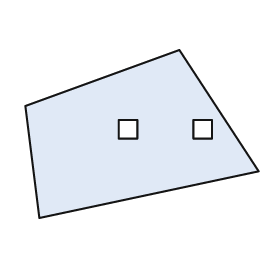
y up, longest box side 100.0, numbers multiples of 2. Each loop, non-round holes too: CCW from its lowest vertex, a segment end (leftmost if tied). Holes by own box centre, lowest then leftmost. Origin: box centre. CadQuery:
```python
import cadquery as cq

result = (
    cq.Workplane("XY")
    .moveTo(-44.0, -36.0)
    .lineTo(50.0, -16.0)
    .lineTo(16.0, 36.0)
    .lineTo(-50.0, 12.0)
    .close()
    .moveTo(-10.0, -2.0)
    .lineTo(-2.0, -2.0)
    .lineTo(-2.0, 6.0)
    .lineTo(-10.0, 6.0)
    .close()
    .moveTo(22.0, -2.0)
    .lineTo(30.0, -2.0)
    .lineTo(30.0, 6.0)
    .lineTo(22.0, 6.0)
    .close()
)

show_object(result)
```